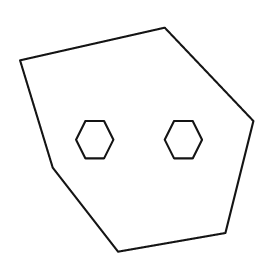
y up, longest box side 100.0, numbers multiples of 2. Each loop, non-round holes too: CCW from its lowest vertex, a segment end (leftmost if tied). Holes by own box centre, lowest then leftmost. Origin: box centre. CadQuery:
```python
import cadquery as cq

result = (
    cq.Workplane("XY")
    .moveTo(-8.0, -48.0)
    .lineTo(38.0, -40.0)
    .lineTo(50.0, 8.0)
    .lineTo(12.0, 48.0)
    .lineTo(-50.0, 34.0)
    .lineTo(-36.0, -12.0)
    .close()
    .moveTo(-22.0, -8.0)
    .lineTo(-14.0, -8.0)
    .lineTo(-10.0, 0.0)
    .lineTo(-14.0, 8.0)
    .lineTo(-22.0, 8.0)
    .lineTo(-26.0, 0.0)
    .close()
    .moveTo(16.0, -8.0)
    .lineTo(24.0, -8.0)
    .lineTo(28.0, 0.0)
    .lineTo(24.0, 8.0)
    .lineTo(16.0, 8.0)
    .lineTo(12.0, 0.0)
    .close()
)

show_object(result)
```